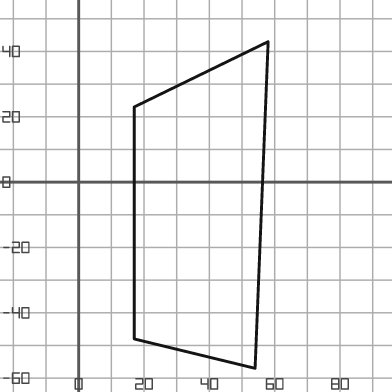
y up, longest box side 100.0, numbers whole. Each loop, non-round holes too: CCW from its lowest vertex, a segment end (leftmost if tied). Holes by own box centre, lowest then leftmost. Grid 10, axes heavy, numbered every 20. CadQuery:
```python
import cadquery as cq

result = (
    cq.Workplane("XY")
    .moveTo(54.0, -57.0)
    .lineTo(58.0, 43.0)
    .lineTo(17.0, 23.0)
    .lineTo(17.0, -48.0)
    .close()
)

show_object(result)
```